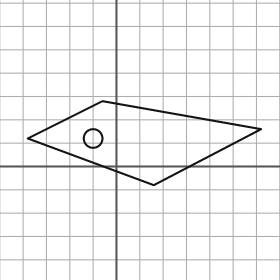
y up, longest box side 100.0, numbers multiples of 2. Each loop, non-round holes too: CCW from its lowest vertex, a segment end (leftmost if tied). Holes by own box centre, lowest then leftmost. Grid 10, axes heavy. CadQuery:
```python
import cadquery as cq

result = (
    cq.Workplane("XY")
    .moveTo(16.0, -8.0)
    .lineTo(62.0, 16.0)
    .lineTo(-6.0, 28.0)
    .lineTo(-38.0, 12.0)
    .close()
    .moveTo(-10.0, 12.0)
    .circle(4.0)
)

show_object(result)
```